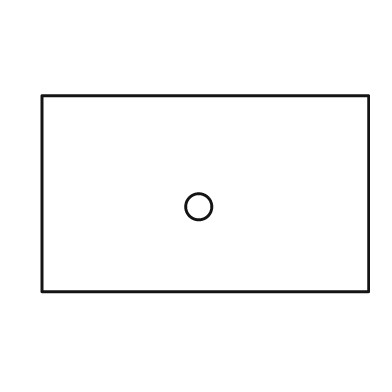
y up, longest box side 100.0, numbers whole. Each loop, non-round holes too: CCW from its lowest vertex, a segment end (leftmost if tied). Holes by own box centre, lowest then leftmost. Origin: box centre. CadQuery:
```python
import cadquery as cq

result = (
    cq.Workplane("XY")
    .moveTo(-50.0, -30.0)
    .lineTo(50.0, -30.0)
    .lineTo(50.0, 30.0)
    .lineTo(-50.0, 30.0)
    .close()
    .moveTo(-2.0, -4.0)
    .circle(4.0)
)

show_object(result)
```